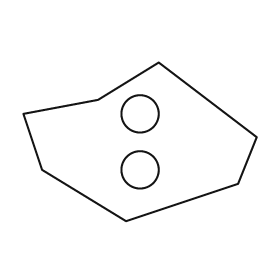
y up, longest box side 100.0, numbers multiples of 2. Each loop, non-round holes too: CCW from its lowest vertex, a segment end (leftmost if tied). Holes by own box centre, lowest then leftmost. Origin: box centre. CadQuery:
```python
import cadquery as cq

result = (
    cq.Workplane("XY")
    .moveTo(-6.0, -34.0)
    .lineTo(42.0, -18.0)
    .lineTo(50.0, 2.0)
    .lineTo(8.0, 34.0)
    .lineTo(-18.0, 18.0)
    .lineTo(-50.0, 12.0)
    .lineTo(-42.0, -12.0)
    .close()
    .moveTo(0.0, -12.0)
    .circle(8.0)
    .moveTo(0.0, 12.0)
    .circle(8.0)
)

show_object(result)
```